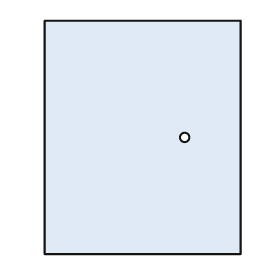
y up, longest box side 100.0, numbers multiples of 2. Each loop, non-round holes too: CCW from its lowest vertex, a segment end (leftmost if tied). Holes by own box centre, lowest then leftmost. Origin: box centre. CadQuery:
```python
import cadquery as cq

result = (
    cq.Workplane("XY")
    .moveTo(-42.0, -50.0)
    .lineTo(42.0, -50.0)
    .lineTo(42.0, 50.0)
    .lineTo(-42.0, 50.0)
    .close()
    .moveTo(18.0, 0.0)
    .circle(2.0)
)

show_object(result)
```